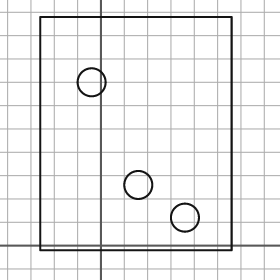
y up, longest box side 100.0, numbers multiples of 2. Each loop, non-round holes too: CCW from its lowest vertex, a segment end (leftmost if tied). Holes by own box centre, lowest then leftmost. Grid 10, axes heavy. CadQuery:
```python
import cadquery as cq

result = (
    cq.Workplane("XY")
    .moveTo(-26.0, -2.0)
    .lineTo(56.0, -2.0)
    .lineTo(56.0, 98.0)
    .lineTo(-26.0, 98.0)
    .close()
    .moveTo(36.0, 12.0)
    .circle(6.0)
    .moveTo(16.0, 26.0)
    .circle(6.0)
    .moveTo(-4.0, 70.0)
    .circle(6.0)
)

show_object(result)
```